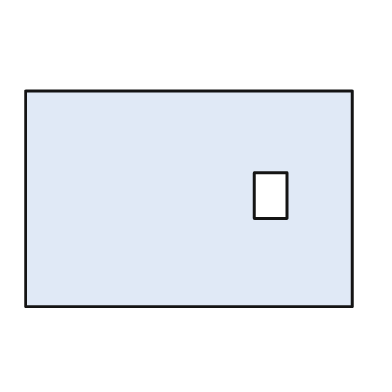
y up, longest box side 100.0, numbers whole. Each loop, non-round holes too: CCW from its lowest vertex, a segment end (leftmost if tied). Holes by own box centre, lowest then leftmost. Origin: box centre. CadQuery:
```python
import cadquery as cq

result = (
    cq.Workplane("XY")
    .moveTo(-50.0, -33.0)
    .lineTo(50.0, -33.0)
    .lineTo(50.0, 33.0)
    .lineTo(-50.0, 33.0)
    .close()
    .moveTo(20.0, -6.0)
    .lineTo(30.0, -6.0)
    .lineTo(30.0, 8.0)
    .lineTo(20.0, 8.0)
    .close()
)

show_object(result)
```